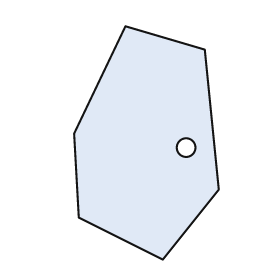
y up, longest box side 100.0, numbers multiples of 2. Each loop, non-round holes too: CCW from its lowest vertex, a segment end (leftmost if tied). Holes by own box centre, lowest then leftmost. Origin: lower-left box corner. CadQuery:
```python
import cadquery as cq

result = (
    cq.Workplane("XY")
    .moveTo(38.0, 0.0)
    .lineTo(62.0, 30.0)
    .lineTo(56.0, 90.0)
    .lineTo(22.0, 100.0)
    .lineTo(0.0, 54.0)
    .lineTo(2.0, 18.0)
    .close()
    .moveTo(48.0, 48.0)
    .circle(4.0)
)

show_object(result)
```